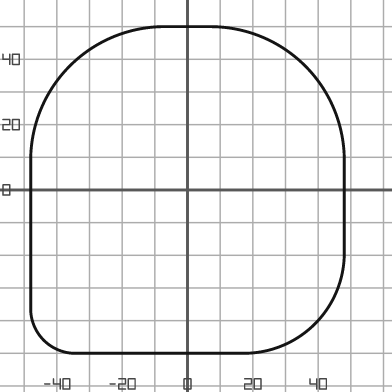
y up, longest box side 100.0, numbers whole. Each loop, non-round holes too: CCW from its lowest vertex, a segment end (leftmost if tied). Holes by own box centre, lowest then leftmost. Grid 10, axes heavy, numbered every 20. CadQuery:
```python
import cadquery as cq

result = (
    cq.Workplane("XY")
    .moveTo(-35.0, -50.0)
    .lineTo(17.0, -50.0)
    .threePointArc((39.0, -41.0), (48.0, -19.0))
    .lineTo(48.0, 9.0)
    .threePointArc((36.0, 38.0), (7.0, 50.0))
    .lineTo(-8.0, 50.0)
    .threePointArc((-36.0, 38.0), (-48.0, 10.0))
    .lineTo(-48.0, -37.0)
    .threePointArc((-44.0, -46.0), (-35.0, -50.0))
    .close()
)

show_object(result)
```